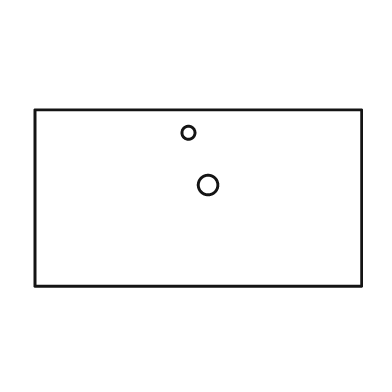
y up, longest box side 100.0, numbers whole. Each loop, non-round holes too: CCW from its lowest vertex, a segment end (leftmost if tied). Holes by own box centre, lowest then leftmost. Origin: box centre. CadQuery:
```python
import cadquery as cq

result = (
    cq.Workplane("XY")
    .moveTo(-50.0, -27.0)
    .lineTo(50.0, -27.0)
    .lineTo(50.0, 27.0)
    .lineTo(-50.0, 27.0)
    .close()
    .moveTo(3.0, 4.0)
    .circle(3.0)
    .moveTo(-3.0, 20.0)
    .circle(2.0)
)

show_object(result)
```